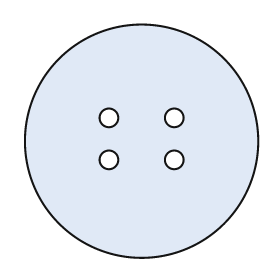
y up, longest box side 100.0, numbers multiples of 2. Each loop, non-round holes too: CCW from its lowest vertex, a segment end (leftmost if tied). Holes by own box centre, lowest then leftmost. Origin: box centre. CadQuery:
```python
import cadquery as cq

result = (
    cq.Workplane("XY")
    .moveTo(0.0, 0.0)
    .circle(50.0)
    .moveTo(-14.0, -8.0)
    .circle(4.0)
    .moveTo(14.0, -8.0)
    .circle(4.0)
    .moveTo(-14.0, 10.0)
    .circle(4.0)
    .moveTo(14.0, 10.0)
    .circle(4.0)
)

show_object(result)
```